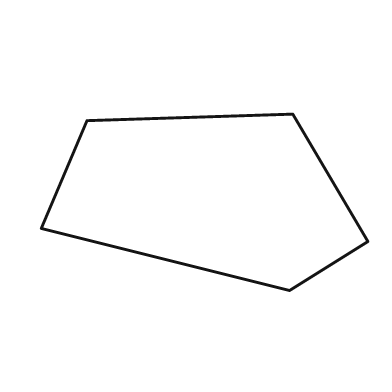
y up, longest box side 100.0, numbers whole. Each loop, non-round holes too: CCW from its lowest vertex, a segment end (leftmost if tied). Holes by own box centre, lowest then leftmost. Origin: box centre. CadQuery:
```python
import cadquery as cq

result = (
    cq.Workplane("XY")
    .moveTo(26.0, -27.0)
    .lineTo(50.0, -12.0)
    .lineTo(27.0, 27.0)
    .lineTo(-36.0, 25.0)
    .lineTo(-50.0, -8.0)
    .close()
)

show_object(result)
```